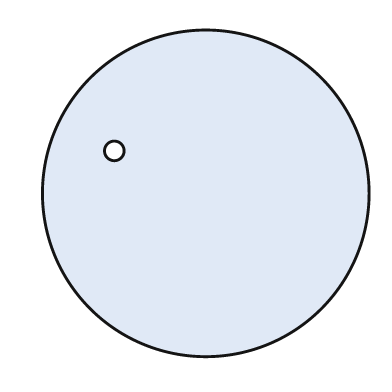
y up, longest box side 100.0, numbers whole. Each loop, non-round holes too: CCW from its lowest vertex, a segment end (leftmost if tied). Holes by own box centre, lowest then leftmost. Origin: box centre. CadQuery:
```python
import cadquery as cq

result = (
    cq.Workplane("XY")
    .moveTo(0.0, 0.0)
    .circle(50.0)
    .moveTo(-28.0, 13.0)
    .circle(3.0)
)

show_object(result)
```